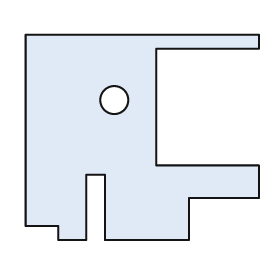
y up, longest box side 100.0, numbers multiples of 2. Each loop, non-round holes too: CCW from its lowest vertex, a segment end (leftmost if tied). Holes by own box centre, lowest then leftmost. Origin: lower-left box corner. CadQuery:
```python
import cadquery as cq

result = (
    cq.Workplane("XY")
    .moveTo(14.0, 0.0)
    .lineTo(26.0, 0.0)
    .lineTo(26.0, 28.0)
    .lineTo(34.0, 28.0)
    .lineTo(34.0, 0.0)
    .lineTo(70.0, 0.0)
    .lineTo(70.0, 18.0)
    .lineTo(100.0, 18.0)
    .lineTo(100.0, 32.0)
    .lineTo(56.0, 32.0)
    .lineTo(56.0, 82.0)
    .lineTo(100.0, 82.0)
    .lineTo(100.0, 88.0)
    .lineTo(0.0, 88.0)
    .lineTo(0.0, 6.0)
    .lineTo(14.0, 6.0)
    .close()
    .moveTo(38.0, 60.0)
    .circle(6.0)
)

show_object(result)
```